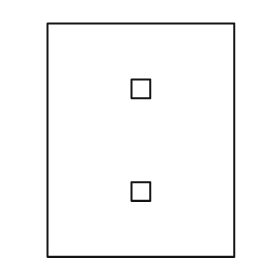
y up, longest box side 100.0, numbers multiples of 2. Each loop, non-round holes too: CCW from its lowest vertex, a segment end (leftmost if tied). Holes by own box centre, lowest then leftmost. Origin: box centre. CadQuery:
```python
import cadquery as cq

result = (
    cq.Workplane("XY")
    .moveTo(-40.0, -50.0)
    .lineTo(40.0, -50.0)
    .lineTo(40.0, 50.0)
    .lineTo(-40.0, 50.0)
    .close()
    .moveTo(-4.0, -26.0)
    .lineTo(4.0, -26.0)
    .lineTo(4.0, -18.0)
    .lineTo(-4.0, -18.0)
    .close()
    .moveTo(-4.0, 18.0)
    .lineTo(4.0, 18.0)
    .lineTo(4.0, 26.0)
    .lineTo(-4.0, 26.0)
    .close()
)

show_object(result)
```